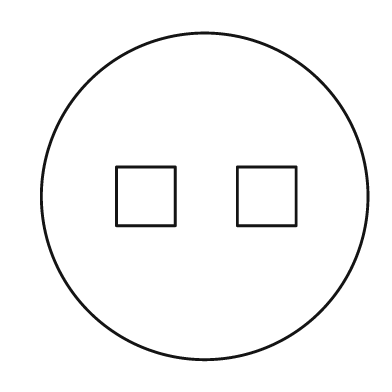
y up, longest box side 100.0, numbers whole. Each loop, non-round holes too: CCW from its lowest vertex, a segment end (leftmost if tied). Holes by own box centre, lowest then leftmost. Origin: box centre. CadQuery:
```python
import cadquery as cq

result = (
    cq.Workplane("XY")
    .moveTo(0.0, 0.0)
    .circle(50.0)
    .moveTo(-27.0, -9.0)
    .lineTo(-9.0, -9.0)
    .lineTo(-9.0, 9.0)
    .lineTo(-27.0, 9.0)
    .close()
    .moveTo(10.0, -9.0)
    .lineTo(28.0, -9.0)
    .lineTo(28.0, 9.0)
    .lineTo(10.0, 9.0)
    .close()
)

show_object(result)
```